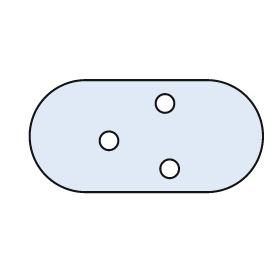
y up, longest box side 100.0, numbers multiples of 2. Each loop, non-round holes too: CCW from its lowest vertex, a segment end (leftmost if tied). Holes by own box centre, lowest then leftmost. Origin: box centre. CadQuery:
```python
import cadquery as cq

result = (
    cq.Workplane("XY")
    .moveTo(-26.0, -24.0)
    .lineTo(26.0, -24.0)
    .threePointArc((50.0, 0.0), (26.0, 24.0))
    .lineTo(-26.0, 24.0)
    .threePointArc((-50.0, 0.0), (-26.0, -24.0))
    .close()
    .moveTo(10.0, -14.0)
    .circle(4.0)
    .moveTo(-16.0, -2.0)
    .circle(4.0)
    .moveTo(8.0, 14.0)
    .circle(4.0)
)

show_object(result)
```